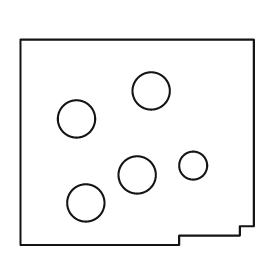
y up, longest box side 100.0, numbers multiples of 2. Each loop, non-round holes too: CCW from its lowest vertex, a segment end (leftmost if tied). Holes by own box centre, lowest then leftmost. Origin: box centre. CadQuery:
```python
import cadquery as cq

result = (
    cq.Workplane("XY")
    .moveTo(-50.0, -44.0)
    .lineTo(18.0, -44.0)
    .lineTo(18.0, -40.0)
    .lineTo(44.0, -40.0)
    .lineTo(44.0, -36.0)
    .lineTo(50.0, -36.0)
    .lineTo(50.0, 44.0)
    .lineTo(-50.0, 44.0)
    .close()
    .moveTo(-22.0, -26.0)
    .circle(8.0)
    .moveTo(0.0, -14.0)
    .circle(8.0)
    .moveTo(24.0, -10.0)
    .circle(6.0)
    .moveTo(-26.0, 10.0)
    .circle(8.0)
    .moveTo(6.0, 22.0)
    .circle(8.0)
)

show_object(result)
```